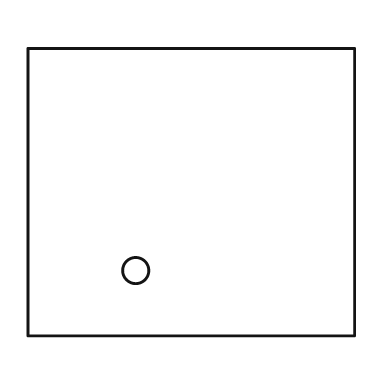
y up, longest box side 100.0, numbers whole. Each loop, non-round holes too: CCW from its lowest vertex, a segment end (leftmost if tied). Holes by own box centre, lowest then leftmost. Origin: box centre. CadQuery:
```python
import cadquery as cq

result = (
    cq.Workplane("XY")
    .moveTo(-50.0, -44.0)
    .lineTo(50.0, -44.0)
    .lineTo(50.0, 44.0)
    .lineTo(-50.0, 44.0)
    .close()
    .moveTo(-17.0, -24.0)
    .circle(4.0)
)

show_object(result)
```